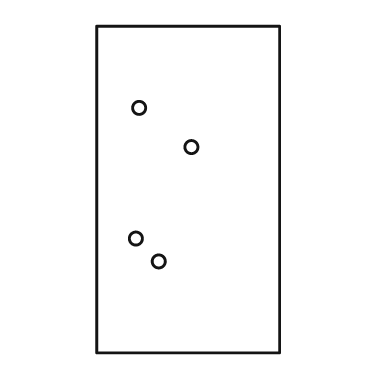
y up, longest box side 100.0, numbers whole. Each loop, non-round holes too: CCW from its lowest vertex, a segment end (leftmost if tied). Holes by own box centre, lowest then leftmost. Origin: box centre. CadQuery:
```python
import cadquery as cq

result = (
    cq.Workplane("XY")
    .moveTo(-28.0, -50.0)
    .lineTo(28.0, -50.0)
    .lineTo(28.0, 50.0)
    .lineTo(-28.0, 50.0)
    .close()
    .moveTo(-9.0, -22.0)
    .circle(2.0)
    .moveTo(-16.0, -15.0)
    .circle(2.0)
    .moveTo(1.0, 13.0)
    .circle(2.0)
    .moveTo(-15.0, 25.0)
    .circle(2.0)
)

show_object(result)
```